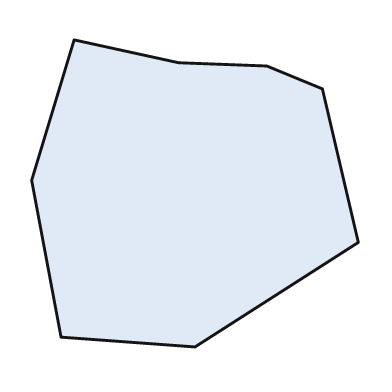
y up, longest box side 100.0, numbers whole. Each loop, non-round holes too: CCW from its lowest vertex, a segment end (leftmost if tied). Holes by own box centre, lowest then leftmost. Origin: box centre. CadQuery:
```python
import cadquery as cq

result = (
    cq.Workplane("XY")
    .moveTo(0.0, -47.0)
    .lineTo(50.0, -15.0)
    .lineTo(39.0, 32.0)
    .lineTo(22.0, 39.0)
    .lineTo(-5.0, 40.0)
    .lineTo(-37.0, 47.0)
    .lineTo(-50.0, 4.0)
    .lineTo(-41.0, -44.0)
    .close()
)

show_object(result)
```